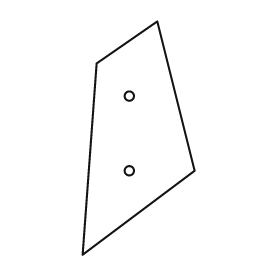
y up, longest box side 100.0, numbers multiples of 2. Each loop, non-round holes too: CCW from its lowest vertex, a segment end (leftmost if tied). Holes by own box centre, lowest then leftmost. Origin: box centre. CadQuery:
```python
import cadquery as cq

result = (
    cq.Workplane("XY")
    .moveTo(-24.0, -50.0)
    .lineTo(24.0, -14.0)
    .lineTo(8.0, 50.0)
    .lineTo(-18.0, 32.0)
    .close()
    .moveTo(-4.0, -14.0)
    .circle(2.0)
    .moveTo(-4.0, 18.0)
    .circle(2.0)
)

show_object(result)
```